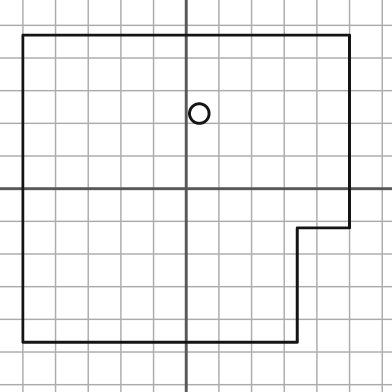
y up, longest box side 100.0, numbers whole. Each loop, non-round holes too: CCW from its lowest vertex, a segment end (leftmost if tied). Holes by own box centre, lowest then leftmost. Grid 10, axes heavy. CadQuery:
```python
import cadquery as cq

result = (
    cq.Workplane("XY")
    .moveTo(-50.0, -47.0)
    .lineTo(34.0, -47.0)
    .lineTo(34.0, -12.0)
    .lineTo(50.0, -12.0)
    .lineTo(50.0, 47.0)
    .lineTo(-50.0, 47.0)
    .close()
    .moveTo(4.0, 23.0)
    .circle(3.0)
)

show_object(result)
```